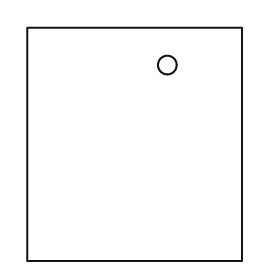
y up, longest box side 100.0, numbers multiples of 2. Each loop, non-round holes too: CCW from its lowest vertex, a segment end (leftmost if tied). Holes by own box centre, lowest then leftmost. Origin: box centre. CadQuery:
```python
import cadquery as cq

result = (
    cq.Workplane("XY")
    .moveTo(-46.0, -50.0)
    .lineTo(46.0, -50.0)
    .lineTo(46.0, 50.0)
    .lineTo(-46.0, 50.0)
    .close()
    .moveTo(14.0, 34.0)
    .circle(4.0)
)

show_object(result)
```